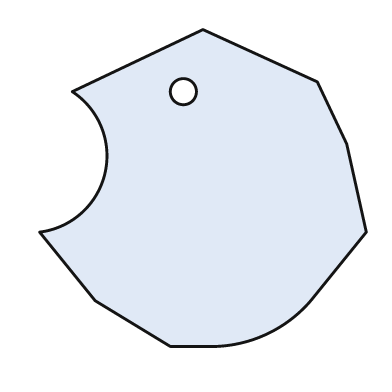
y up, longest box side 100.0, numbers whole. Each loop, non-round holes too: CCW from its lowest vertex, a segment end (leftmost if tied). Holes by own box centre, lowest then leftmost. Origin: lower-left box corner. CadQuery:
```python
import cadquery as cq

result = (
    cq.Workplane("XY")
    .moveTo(40.0, 0.0)
    .lineTo(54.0, 0.0)
    .threePointArc((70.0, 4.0), (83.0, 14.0))
    .lineTo(100.0, 35.0)
    .lineTo(94.0, 62.0)
    .lineTo(85.0, 81.0)
    .lineTo(50.0, 97.0)
    .lineTo(10.0, 78.0)
    .threePointArc((20.0, 53.0), (0.0, 35.0))
    .lineTo(17.0, 14.0)
    .close()
    .moveTo(44.0, 78.0)
    .circle(4.0)
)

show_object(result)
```